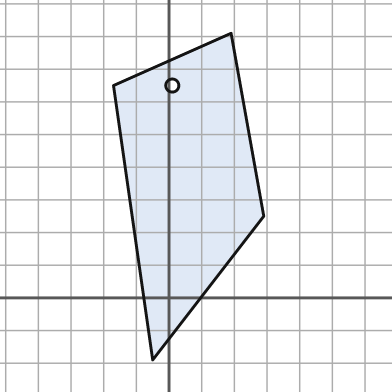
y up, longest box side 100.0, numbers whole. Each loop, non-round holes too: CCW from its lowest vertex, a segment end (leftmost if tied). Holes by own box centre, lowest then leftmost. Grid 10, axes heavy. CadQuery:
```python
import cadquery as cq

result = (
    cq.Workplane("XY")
    .moveTo(-5.0, -19.0)
    .lineTo(29.0, 25.0)
    .lineTo(19.0, 81.0)
    .lineTo(-17.0, 65.0)
    .close()
    .moveTo(1.0, 65.0)
    .circle(2.0)
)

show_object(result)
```